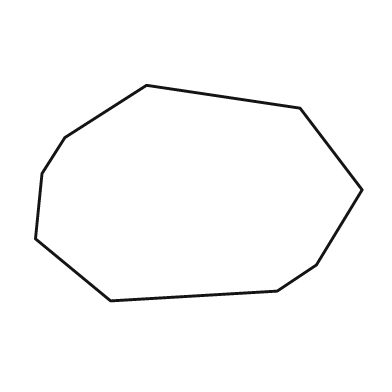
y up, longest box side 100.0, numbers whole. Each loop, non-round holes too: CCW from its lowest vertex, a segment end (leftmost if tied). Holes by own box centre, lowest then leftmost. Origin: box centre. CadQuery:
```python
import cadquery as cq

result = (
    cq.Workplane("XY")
    .moveTo(-27.0, -33.0)
    .lineTo(24.0, -30.0)
    .lineTo(36.0, -22.0)
    .lineTo(50.0, 1.0)
    .lineTo(31.0, 26.0)
    .lineTo(-16.0, 33.0)
    .lineTo(-41.0, 17.0)
    .lineTo(-48.0, 6.0)
    .lineTo(-50.0, -14.0)
    .close()
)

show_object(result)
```